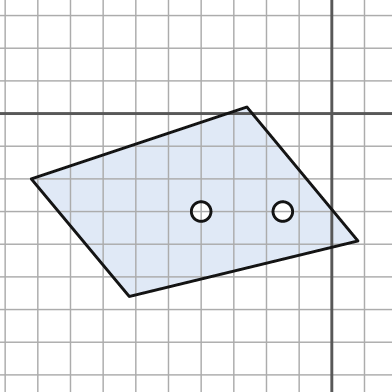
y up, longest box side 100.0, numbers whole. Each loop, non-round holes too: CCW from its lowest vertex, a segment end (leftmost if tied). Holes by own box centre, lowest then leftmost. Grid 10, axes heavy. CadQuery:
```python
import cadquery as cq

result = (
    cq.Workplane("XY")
    .moveTo(-62.0, -56.0)
    .lineTo(8.0, -39.0)
    .lineTo(-26.0, 2.0)
    .lineTo(-92.0, -20.0)
    .close()
    .moveTo(-40.0, -30.0)
    .circle(3.0)
    .moveTo(-15.0, -30.0)
    .circle(3.0)
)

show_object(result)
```